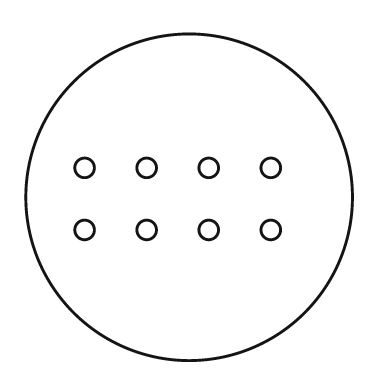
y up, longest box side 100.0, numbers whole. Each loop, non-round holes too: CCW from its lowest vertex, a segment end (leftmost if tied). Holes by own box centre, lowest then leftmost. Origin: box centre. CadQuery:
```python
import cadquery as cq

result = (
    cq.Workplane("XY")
    .moveTo(0.0, 0.0)
    .circle(50.0)
    .moveTo(-32.0, -10.0)
    .circle(3.0)
    .moveTo(-13.0, -10.0)
    .circle(3.0)
    .moveTo(6.0, -10.0)
    .circle(3.0)
    .moveTo(25.0, -10.0)
    .circle(3.0)
    .moveTo(-32.0, 9.0)
    .circle(3.0)
    .moveTo(-13.0, 9.0)
    .circle(3.0)
    .moveTo(6.0, 9.0)
    .circle(3.0)
    .moveTo(25.0, 9.0)
    .circle(3.0)
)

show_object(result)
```